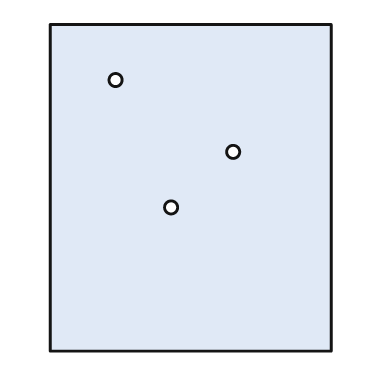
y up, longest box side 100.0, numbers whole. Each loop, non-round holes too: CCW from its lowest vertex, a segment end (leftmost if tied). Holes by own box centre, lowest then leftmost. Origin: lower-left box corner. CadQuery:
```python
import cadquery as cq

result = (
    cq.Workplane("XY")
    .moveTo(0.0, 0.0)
    .lineTo(86.0, 0.0)
    .lineTo(86.0, 100.0)
    .lineTo(0.0, 100.0)
    .close()
    .moveTo(37.0, 44.0)
    .circle(2.0)
    .moveTo(56.0, 61.0)
    .circle(2.0)
    .moveTo(20.0, 83.0)
    .circle(2.0)
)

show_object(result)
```